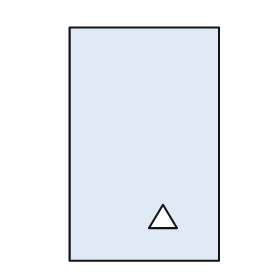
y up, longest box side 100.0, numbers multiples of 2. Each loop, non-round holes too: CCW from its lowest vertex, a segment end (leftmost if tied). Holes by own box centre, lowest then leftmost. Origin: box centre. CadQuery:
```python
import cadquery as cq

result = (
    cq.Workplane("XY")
    .moveTo(-32.0, -50.0)
    .lineTo(32.0, -50.0)
    .lineTo(32.0, 50.0)
    .lineTo(-32.0, 50.0)
    .close()
    .moveTo(2.0, -36.0)
    .lineTo(14.0, -36.0)
    .lineTo(8.0, -26.0)
    .close()
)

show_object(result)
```